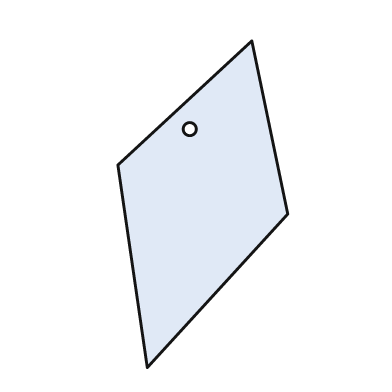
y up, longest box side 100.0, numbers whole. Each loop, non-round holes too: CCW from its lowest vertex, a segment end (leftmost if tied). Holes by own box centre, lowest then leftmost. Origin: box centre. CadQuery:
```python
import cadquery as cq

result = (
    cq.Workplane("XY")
    .moveTo(-17.0, -50.0)
    .lineTo(26.0, -3.0)
    .lineTo(15.0, 50.0)
    .lineTo(-26.0, 12.0)
    .close()
    .moveTo(-4.0, 23.0)
    .circle(2.0)
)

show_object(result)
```